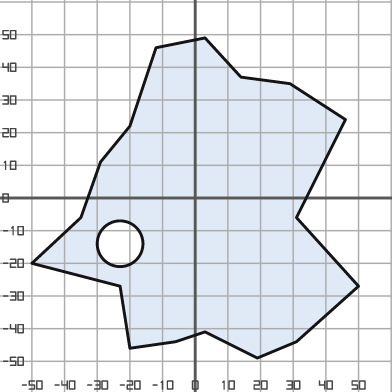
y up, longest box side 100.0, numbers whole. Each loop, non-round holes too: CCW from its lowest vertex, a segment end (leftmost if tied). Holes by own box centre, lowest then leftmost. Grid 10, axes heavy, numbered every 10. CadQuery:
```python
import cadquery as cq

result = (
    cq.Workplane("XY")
    .moveTo(19.0, -49.0)
    .lineTo(31.0, -44.0)
    .lineTo(50.0, -27.0)
    .lineTo(31.0, -6.0)
    .lineTo(46.0, 24.0)
    .lineTo(29.0, 35.0)
    .lineTo(14.0, 37.0)
    .lineTo(3.0, 49.0)
    .lineTo(-12.0, 46.0)
    .lineTo(-20.0, 22.0)
    .lineTo(-29.0, 11.0)
    .lineTo(-35.0, -6.0)
    .lineTo(-50.0, -20.0)
    .lineTo(-23.0, -27.0)
    .lineTo(-20.0, -46.0)
    .lineTo(-6.0, -44.0)
    .lineTo(3.0, -41.0)
    .close()
    .moveTo(-23.0, -14.0)
    .circle(7.0)
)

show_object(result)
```